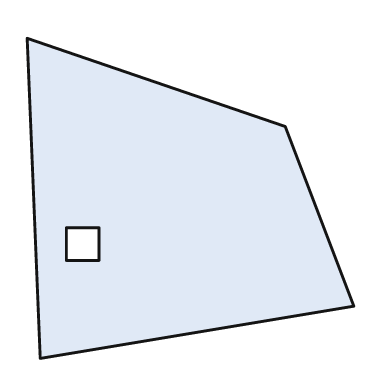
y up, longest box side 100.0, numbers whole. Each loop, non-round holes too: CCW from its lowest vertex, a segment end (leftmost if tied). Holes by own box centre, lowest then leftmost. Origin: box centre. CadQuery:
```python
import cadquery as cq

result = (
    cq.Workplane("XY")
    .moveTo(-46.0, -49.0)
    .lineTo(50.0, -33.0)
    .lineTo(29.0, 22.0)
    .lineTo(-50.0, 49.0)
    .close()
    .moveTo(-38.0, -19.0)
    .lineTo(-28.0, -19.0)
    .lineTo(-28.0, -9.0)
    .lineTo(-38.0, -9.0)
    .close()
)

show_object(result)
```